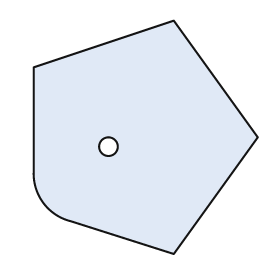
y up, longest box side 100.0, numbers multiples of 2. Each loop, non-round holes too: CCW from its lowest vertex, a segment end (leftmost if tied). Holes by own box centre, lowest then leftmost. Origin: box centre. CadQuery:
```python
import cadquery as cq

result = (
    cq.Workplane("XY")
    .moveTo(12.0, -50.0)
    .lineTo(48.0, 0.0)
    .lineTo(12.0, 50.0)
    .lineTo(-48.0, 30.0)
    .lineTo(-48.0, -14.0)
    .threePointArc((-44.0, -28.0), (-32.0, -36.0))
    .close()
    .moveTo(-16.0, -4.0)
    .circle(4.0)
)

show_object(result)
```